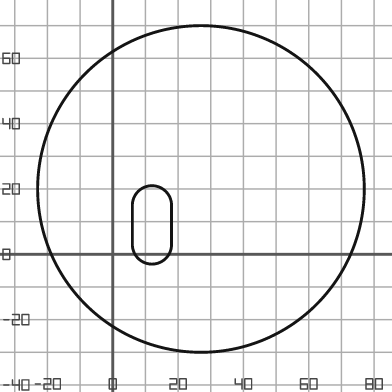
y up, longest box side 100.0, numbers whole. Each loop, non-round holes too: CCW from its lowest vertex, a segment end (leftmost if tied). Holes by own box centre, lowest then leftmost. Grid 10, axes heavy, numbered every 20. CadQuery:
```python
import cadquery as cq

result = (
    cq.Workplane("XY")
    .moveTo(27.0, 20.0)
    .circle(50.0)
    .moveTo(6.0, 3.0)
    .threePointArc((12.0, -3.0), (18.0, 3.0))
    .lineTo(18.0, 15.0)
    .threePointArc((12.0, 21.0), (6.0, 15.0))
    .close()
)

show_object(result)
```